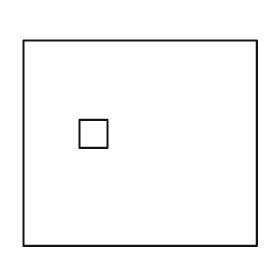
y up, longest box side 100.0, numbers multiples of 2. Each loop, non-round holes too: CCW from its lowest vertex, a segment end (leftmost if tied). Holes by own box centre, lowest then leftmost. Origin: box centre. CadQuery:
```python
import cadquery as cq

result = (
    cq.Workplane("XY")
    .moveTo(-50.0, -44.0)
    .lineTo(50.0, -44.0)
    .lineTo(50.0, 44.0)
    .lineTo(-50.0, 44.0)
    .close()
    .moveTo(-26.0, -2.0)
    .lineTo(-14.0, -2.0)
    .lineTo(-14.0, 10.0)
    .lineTo(-26.0, 10.0)
    .close()
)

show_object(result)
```